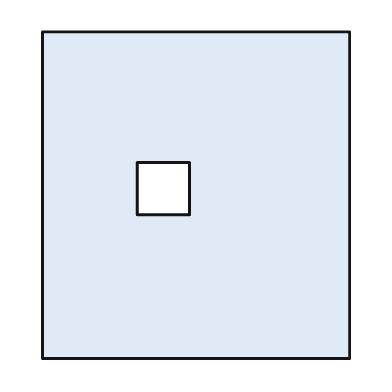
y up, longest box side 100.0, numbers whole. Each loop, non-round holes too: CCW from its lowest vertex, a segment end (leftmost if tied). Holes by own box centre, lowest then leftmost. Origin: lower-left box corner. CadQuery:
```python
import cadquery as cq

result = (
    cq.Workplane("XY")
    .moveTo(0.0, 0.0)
    .lineTo(94.0, 0.0)
    .lineTo(94.0, 100.0)
    .lineTo(0.0, 100.0)
    .close()
    .moveTo(29.0, 44.0)
    .lineTo(45.0, 44.0)
    .lineTo(45.0, 60.0)
    .lineTo(29.0, 60.0)
    .close()
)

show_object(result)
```